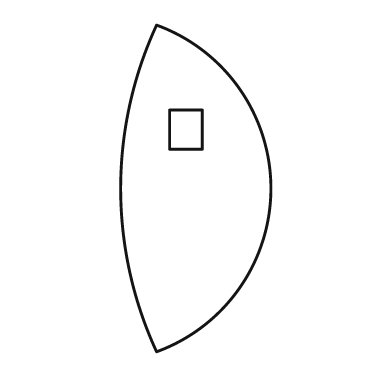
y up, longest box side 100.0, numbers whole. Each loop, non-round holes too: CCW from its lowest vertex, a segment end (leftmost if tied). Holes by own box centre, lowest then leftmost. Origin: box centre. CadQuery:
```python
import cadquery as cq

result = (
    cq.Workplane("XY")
    .moveTo(-12.0, -50.0)
    .threePointArc((23.0, 0.0), (-12.0, 50.0))
    .threePointArc((-23.0, 0.0), (-12.0, -50.0))
    .close()
    .moveTo(-8.0, 12.0)
    .lineTo(2.0, 12.0)
    .lineTo(2.0, 24.0)
    .lineTo(-8.0, 24.0)
    .close()
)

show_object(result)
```